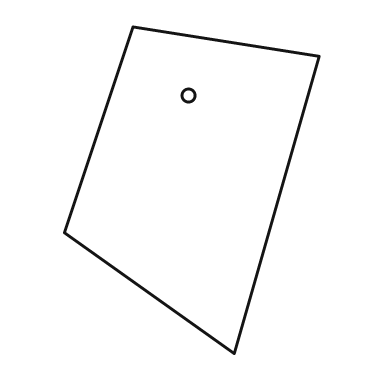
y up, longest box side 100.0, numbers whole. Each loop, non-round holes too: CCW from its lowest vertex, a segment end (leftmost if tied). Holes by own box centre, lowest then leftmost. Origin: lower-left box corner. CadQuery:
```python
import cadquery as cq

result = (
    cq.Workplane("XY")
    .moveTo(52.0, 0.0)
    .lineTo(78.0, 91.0)
    .lineTo(21.0, 100.0)
    .lineTo(0.0, 37.0)
    .close()
    .moveTo(38.0, 79.0)
    .circle(2.0)
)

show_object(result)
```